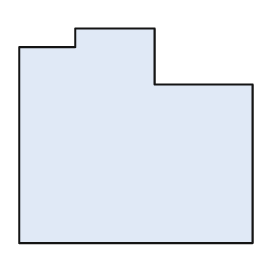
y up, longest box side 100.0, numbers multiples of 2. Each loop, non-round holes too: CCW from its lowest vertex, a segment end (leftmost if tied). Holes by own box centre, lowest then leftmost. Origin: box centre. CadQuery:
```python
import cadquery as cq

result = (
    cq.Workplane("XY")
    .moveTo(-50.0, -46.0)
    .lineTo(50.0, -46.0)
    .lineTo(50.0, 22.0)
    .lineTo(8.0, 22.0)
    .lineTo(8.0, 46.0)
    .lineTo(-26.0, 46.0)
    .lineTo(-26.0, 38.0)
    .lineTo(-50.0, 38.0)
    .close()
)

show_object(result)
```